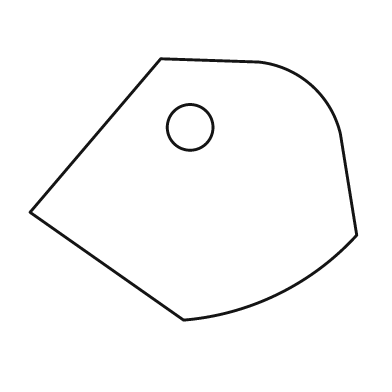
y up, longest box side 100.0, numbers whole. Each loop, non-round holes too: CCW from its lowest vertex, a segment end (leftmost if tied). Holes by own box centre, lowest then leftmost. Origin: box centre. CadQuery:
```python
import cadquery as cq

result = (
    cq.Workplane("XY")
    .moveTo(-3.0, -40.0)
    .threePointArc((26.0, -32.0), (50.0, -14.0))
    .lineTo(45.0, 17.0)
    .threePointArc((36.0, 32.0), (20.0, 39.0))
    .lineTo(-10.0, 40.0)
    .lineTo(-50.0, -7.0)
    .close()
    .moveTo(-1.0, 19.0)
    .circle(7.0)
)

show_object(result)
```